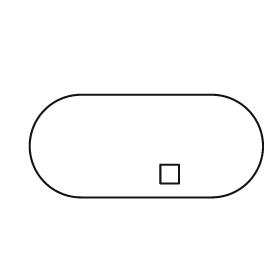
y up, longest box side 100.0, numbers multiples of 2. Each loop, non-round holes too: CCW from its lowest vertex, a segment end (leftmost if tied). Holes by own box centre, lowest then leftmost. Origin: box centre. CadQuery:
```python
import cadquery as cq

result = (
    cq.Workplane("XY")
    .moveTo(-28.0, -22.0)
    .lineTo(28.0, -22.0)
    .threePointArc((50.0, 0.0), (28.0, 22.0))
    .lineTo(-28.0, 22.0)
    .threePointArc((-50.0, 0.0), (-28.0, -22.0))
    .close()
    .moveTo(6.0, -16.0)
    .lineTo(14.0, -16.0)
    .lineTo(14.0, -8.0)
    .lineTo(6.0, -8.0)
    .close()
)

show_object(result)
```